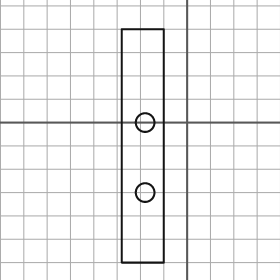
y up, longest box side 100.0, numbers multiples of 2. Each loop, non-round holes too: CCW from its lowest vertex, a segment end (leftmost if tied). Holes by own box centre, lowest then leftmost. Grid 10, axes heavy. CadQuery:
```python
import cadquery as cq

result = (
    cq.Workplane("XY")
    .moveTo(-28.0, -60.0)
    .lineTo(-10.0, -60.0)
    .lineTo(-10.0, 40.0)
    .lineTo(-28.0, 40.0)
    .close()
    .moveTo(-18.0, -30.0)
    .circle(4.0)
    .moveTo(-18.0, 0.0)
    .circle(4.0)
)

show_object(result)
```